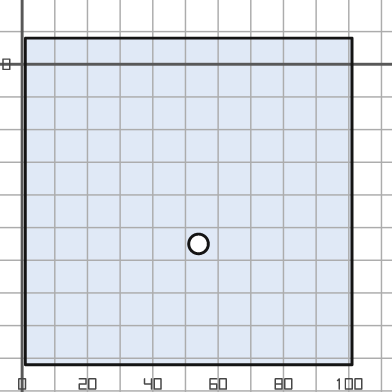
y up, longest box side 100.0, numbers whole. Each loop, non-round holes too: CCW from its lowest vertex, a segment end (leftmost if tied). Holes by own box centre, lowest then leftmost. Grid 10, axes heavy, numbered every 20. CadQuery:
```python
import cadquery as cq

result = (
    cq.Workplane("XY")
    .moveTo(1.0, -92.0)
    .lineTo(101.0, -92.0)
    .lineTo(101.0, 8.0)
    .lineTo(1.0, 8.0)
    .close()
    .moveTo(54.0, -55.0)
    .circle(3.0)
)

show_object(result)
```